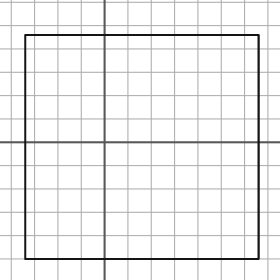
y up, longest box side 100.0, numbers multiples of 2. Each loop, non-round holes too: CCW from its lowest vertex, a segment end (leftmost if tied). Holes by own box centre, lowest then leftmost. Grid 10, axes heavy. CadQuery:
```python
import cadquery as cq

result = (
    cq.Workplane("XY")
    .moveTo(-34.0, -50.0)
    .lineTo(66.0, -50.0)
    .lineTo(66.0, 46.0)
    .lineTo(-34.0, 46.0)
    .close()
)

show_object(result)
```